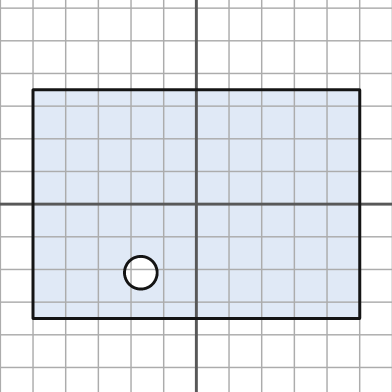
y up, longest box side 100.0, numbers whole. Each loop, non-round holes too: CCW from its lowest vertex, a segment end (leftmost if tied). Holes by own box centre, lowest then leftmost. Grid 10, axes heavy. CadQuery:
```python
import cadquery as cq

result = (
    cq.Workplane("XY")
    .moveTo(-50.0, -35.0)
    .lineTo(50.0, -35.0)
    .lineTo(50.0, 35.0)
    .lineTo(-50.0, 35.0)
    .close()
    .moveTo(-17.0, -21.0)
    .circle(5.0)
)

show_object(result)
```